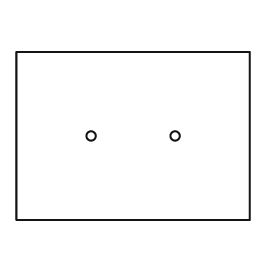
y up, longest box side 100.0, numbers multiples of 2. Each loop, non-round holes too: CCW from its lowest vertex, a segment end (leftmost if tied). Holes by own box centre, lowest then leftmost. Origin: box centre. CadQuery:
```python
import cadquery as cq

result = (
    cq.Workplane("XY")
    .moveTo(-50.0, -36.0)
    .lineTo(50.0, -36.0)
    .lineTo(50.0, 36.0)
    .lineTo(-50.0, 36.0)
    .close()
    .moveTo(-18.0, 0.0)
    .circle(2.0)
    .moveTo(18.0, 0.0)
    .circle(2.0)
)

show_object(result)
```